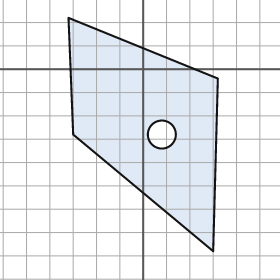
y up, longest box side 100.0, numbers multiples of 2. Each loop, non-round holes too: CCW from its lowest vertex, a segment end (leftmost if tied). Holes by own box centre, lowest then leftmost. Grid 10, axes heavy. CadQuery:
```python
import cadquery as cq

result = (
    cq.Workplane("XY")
    .moveTo(30.0, -78.0)
    .lineTo(32.0, -4.0)
    .lineTo(-32.0, 22.0)
    .lineTo(-30.0, -28.0)
    .close()
    .moveTo(8.0, -28.0)
    .circle(6.0)
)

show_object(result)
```